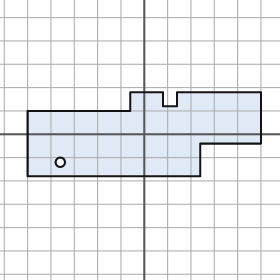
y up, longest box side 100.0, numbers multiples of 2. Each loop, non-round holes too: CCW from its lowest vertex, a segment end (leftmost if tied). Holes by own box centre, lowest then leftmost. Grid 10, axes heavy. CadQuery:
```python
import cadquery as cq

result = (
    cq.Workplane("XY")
    .moveTo(-50.0, -18.0)
    .lineTo(24.0, -18.0)
    .lineTo(24.0, -4.0)
    .lineTo(50.0, -4.0)
    .lineTo(50.0, 18.0)
    .lineTo(14.0, 18.0)
    .lineTo(14.0, 12.0)
    .lineTo(8.0, 12.0)
    .lineTo(8.0, 18.0)
    .lineTo(-6.0, 18.0)
    .lineTo(-6.0, 10.0)
    .lineTo(-50.0, 10.0)
    .close()
    .moveTo(-36.0, -12.0)
    .circle(2.0)
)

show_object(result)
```